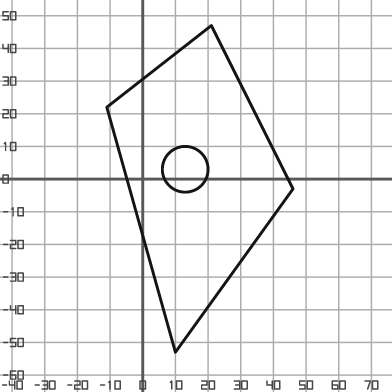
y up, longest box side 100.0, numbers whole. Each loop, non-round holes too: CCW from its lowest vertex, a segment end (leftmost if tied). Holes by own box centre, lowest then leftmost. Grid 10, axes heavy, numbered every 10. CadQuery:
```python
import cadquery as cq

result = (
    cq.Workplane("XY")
    .moveTo(10.0, -53.0)
    .lineTo(46.0, -3.0)
    .lineTo(21.0, 47.0)
    .lineTo(-11.0, 22.0)
    .close()
    .moveTo(13.0, 3.0)
    .circle(7.0)
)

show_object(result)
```